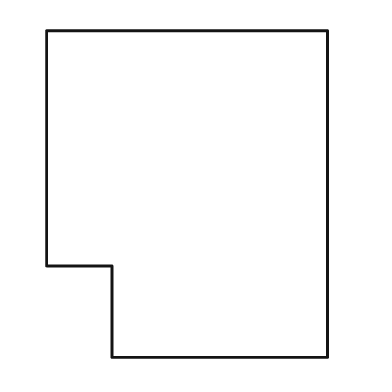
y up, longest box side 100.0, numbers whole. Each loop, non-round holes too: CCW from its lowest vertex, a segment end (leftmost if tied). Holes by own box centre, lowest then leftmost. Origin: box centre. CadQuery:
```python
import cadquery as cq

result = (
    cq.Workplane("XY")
    .moveTo(-23.0, -50.0)
    .lineTo(43.0, -50.0)
    .lineTo(43.0, 50.0)
    .lineTo(-43.0, 50.0)
    .lineTo(-43.0, -22.0)
    .lineTo(-23.0, -22.0)
    .close()
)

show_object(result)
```